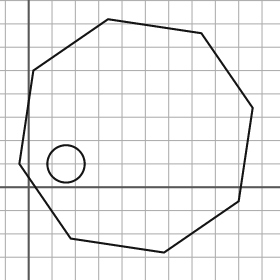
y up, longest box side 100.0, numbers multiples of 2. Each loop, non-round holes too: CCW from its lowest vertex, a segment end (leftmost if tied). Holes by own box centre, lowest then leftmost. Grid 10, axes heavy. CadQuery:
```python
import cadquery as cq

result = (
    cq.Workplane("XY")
    .moveTo(58.0, -28.0)
    .lineTo(90.0, -6.0)
    .lineTo(96.0, 34.0)
    .lineTo(74.0, 66.0)
    .lineTo(34.0, 72.0)
    .lineTo(2.0, 50.0)
    .lineTo(-4.0, 10.0)
    .lineTo(18.0, -22.0)
    .close()
    .moveTo(16.0, 10.0)
    .circle(8.0)
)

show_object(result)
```